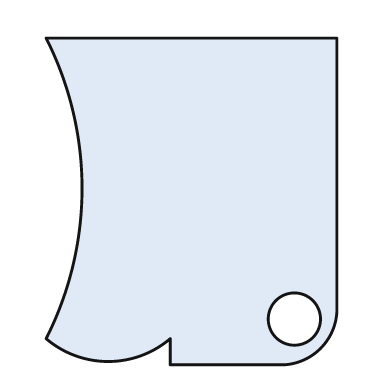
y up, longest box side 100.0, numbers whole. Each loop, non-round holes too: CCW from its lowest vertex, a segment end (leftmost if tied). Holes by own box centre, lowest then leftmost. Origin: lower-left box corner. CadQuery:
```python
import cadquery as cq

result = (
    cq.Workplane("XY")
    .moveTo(38.0, 0.0)
    .lineTo(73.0, 0.0)
    .threePointArc((84.0, 5.0), (89.0, 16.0))
    .lineTo(89.0, 100.0)
    .lineTo(0.0, 100.0)
    .threePointArc((11.0, 54.0), (0.0, 8.0))
    .threePointArc((19.0, 1.0), (38.0, 8.0))
    .close()
    .moveTo(76.0, 14.0)
    .circle(8.0)
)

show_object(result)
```